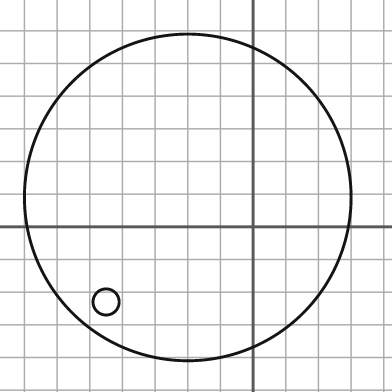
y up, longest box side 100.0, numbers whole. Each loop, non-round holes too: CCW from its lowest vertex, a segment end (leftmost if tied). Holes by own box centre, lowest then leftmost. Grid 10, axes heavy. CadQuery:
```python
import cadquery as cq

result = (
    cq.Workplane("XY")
    .moveTo(-20.0, 9.0)
    .circle(50.0)
    .moveTo(-45.0, -23.0)
    .circle(4.0)
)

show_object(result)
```